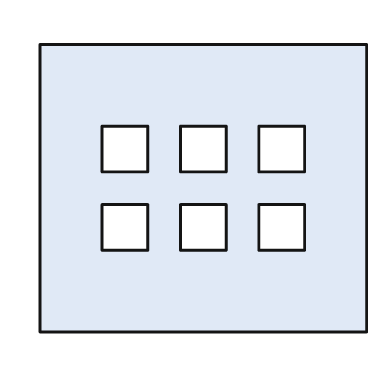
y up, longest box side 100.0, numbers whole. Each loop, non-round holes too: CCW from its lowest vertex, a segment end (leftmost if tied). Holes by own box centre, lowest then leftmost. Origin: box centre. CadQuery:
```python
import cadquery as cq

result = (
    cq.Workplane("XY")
    .moveTo(-50.0, -44.0)
    .lineTo(50.0, -44.0)
    .lineTo(50.0, 44.0)
    .lineTo(-50.0, 44.0)
    .close()
    .moveTo(-31.0, -19.0)
    .lineTo(-17.0, -19.0)
    .lineTo(-17.0, -5.0)
    .lineTo(-31.0, -5.0)
    .close()
    .moveTo(-7.0, -19.0)
    .lineTo(7.0, -19.0)
    .lineTo(7.0, -5.0)
    .lineTo(-7.0, -5.0)
    .close()
    .moveTo(17.0, -19.0)
    .lineTo(31.0, -19.0)
    .lineTo(31.0, -5.0)
    .lineTo(17.0, -5.0)
    .close()
    .moveTo(-31.0, 5.0)
    .lineTo(-17.0, 5.0)
    .lineTo(-17.0, 19.0)
    .lineTo(-31.0, 19.0)
    .close()
    .moveTo(-7.0, 5.0)
    .lineTo(7.0, 5.0)
    .lineTo(7.0, 19.0)
    .lineTo(-7.0, 19.0)
    .close()
    .moveTo(17.0, 5.0)
    .lineTo(31.0, 5.0)
    .lineTo(31.0, 19.0)
    .lineTo(17.0, 19.0)
    .close()
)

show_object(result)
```